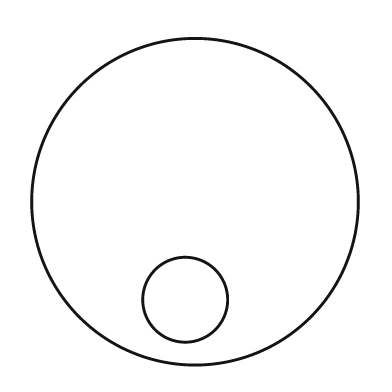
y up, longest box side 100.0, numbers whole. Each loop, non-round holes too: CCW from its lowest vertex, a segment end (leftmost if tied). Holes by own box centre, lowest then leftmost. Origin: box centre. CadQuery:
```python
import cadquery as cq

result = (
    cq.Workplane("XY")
    .moveTo(0.0, 0.0)
    .circle(50.0)
    .moveTo(-3.0, -30.0)
    .circle(13.0)
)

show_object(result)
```